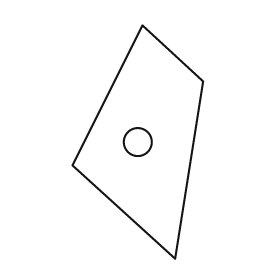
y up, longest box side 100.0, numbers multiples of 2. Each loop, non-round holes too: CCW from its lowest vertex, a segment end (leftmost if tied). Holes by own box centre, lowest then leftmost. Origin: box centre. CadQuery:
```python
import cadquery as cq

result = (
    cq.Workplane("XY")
    .moveTo(16.0, -50.0)
    .lineTo(28.0, 26.0)
    .lineTo(2.0, 50.0)
    .lineTo(-28.0, -10.0)
    .close()
    .moveTo(0.0, 0.0)
    .circle(6.0)
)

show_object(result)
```